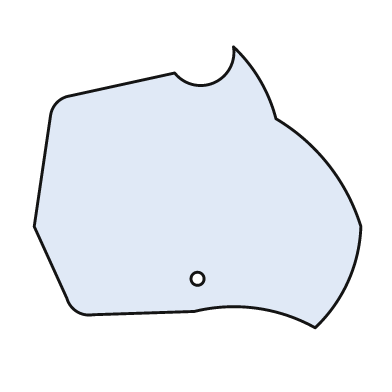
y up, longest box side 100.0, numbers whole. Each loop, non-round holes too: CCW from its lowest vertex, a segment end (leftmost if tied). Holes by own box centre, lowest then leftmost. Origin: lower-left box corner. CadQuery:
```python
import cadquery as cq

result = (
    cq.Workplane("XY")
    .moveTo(86.0, 0.0)
    .threePointArc((96.0, 14.0), (100.0, 31.0))
    .threePointArc((90.0, 50.0), (74.0, 64.0))
    .threePointArc((69.0, 76.0), (61.0, 86.0))
    .threePointArc((55.0, 75.0), (43.0, 78.0))
    .lineTo(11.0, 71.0)
    .threePointArc((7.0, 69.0), (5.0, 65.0))
    .lineTo(0.0, 31.0)
    .lineTo(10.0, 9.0)
    .threePointArc((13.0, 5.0), (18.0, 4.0))
    .lineTo(49.0, 5.0)
    .threePointArc((68.0, 6.0), (86.0, 0.0))
    .close()
    .moveTo(50.0, 15.0)
    .circle(2.0)
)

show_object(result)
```